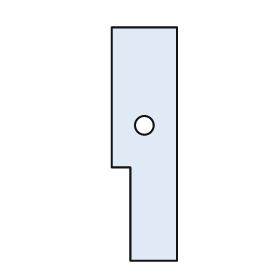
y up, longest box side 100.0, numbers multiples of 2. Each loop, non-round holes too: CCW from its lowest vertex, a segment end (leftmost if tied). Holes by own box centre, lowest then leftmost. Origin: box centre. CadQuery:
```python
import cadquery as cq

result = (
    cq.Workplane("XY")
    .moveTo(-6.0, -50.0)
    .lineTo(14.0, -50.0)
    .lineTo(14.0, 50.0)
    .lineTo(-14.0, 50.0)
    .lineTo(-14.0, -10.0)
    .lineTo(-6.0, -10.0)
    .close()
    .moveTo(0.0, 8.0)
    .circle(4.0)
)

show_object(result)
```